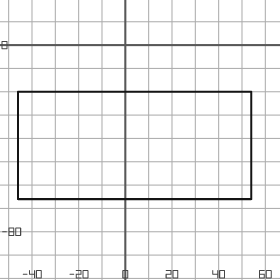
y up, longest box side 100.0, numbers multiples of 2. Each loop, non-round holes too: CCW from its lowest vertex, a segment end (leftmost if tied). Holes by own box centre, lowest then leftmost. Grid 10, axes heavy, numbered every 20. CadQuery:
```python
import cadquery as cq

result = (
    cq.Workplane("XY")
    .moveTo(-46.0, -66.0)
    .lineTo(54.0, -66.0)
    .lineTo(54.0, -20.0)
    .lineTo(-46.0, -20.0)
    .close()
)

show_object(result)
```